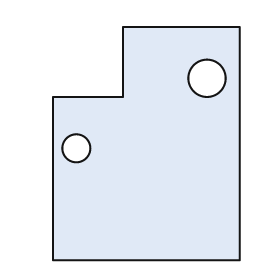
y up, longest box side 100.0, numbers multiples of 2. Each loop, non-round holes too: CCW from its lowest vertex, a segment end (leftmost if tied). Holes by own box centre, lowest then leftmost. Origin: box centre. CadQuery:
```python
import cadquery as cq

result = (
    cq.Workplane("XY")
    .moveTo(-40.0, -50.0)
    .lineTo(40.0, -50.0)
    .lineTo(40.0, 50.0)
    .lineTo(-10.0, 50.0)
    .lineTo(-10.0, 20.0)
    .lineTo(-40.0, 20.0)
    .close()
    .moveTo(-30.0, -2.0)
    .circle(6.0)
    .moveTo(26.0, 28.0)
    .circle(8.0)
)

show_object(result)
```